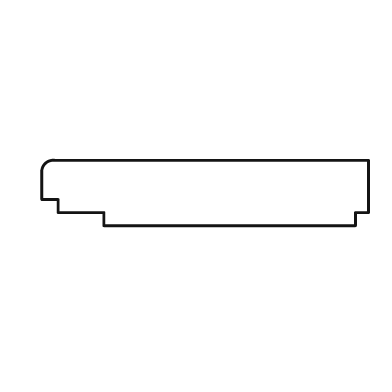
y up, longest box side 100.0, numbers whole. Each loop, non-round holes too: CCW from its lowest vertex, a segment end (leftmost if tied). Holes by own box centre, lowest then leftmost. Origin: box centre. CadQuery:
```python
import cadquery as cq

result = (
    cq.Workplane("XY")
    .moveTo(-31.0, -10.0)
    .lineTo(46.0, -10.0)
    .lineTo(46.0, -6.0)
    .lineTo(50.0, -6.0)
    .lineTo(50.0, 10.0)
    .lineTo(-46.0, 10.0)
    .threePointArc((-49.0, 9.0), (-50.0, 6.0))
    .lineTo(-50.0, -2.0)
    .lineTo(-45.0, -2.0)
    .lineTo(-45.0, -6.0)
    .lineTo(-31.0, -6.0)
    .close()
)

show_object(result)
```